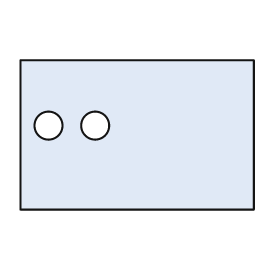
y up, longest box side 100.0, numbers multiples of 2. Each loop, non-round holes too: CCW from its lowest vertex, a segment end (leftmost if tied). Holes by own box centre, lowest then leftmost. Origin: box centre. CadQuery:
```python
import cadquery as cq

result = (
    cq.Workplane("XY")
    .moveTo(-50.0, -32.0)
    .lineTo(50.0, -32.0)
    .lineTo(50.0, 32.0)
    .lineTo(-50.0, 32.0)
    .close()
    .moveTo(-38.0, 4.0)
    .circle(6.0)
    .moveTo(-18.0, 4.0)
    .circle(6.0)
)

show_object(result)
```